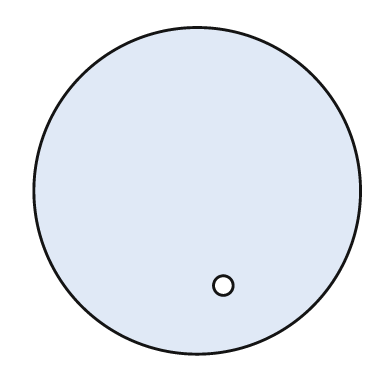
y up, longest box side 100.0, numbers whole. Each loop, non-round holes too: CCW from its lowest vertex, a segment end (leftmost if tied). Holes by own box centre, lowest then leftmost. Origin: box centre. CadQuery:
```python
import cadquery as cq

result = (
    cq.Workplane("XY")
    .moveTo(0.0, 0.0)
    .circle(50.0)
    .moveTo(8.0, -29.0)
    .circle(3.0)
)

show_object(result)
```